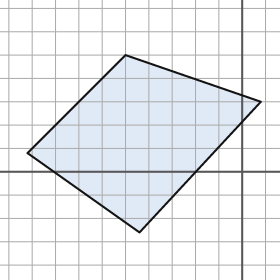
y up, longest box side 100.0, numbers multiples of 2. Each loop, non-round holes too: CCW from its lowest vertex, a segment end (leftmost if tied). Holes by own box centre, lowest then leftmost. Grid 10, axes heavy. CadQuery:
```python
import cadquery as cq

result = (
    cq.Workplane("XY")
    .moveTo(-44.0, -26.0)
    .lineTo(8.0, 30.0)
    .lineTo(-50.0, 50.0)
    .lineTo(-92.0, 8.0)
    .close()
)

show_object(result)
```